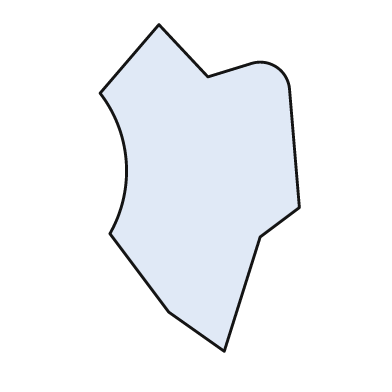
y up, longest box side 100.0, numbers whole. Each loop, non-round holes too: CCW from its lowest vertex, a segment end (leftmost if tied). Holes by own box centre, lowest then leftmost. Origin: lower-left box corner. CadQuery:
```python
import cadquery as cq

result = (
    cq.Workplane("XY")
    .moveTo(38.0, 0.0)
    .lineTo(49.0, 35.0)
    .lineTo(61.0, 44.0)
    .lineTo(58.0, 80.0)
    .threePointArc((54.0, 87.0), (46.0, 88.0))
    .lineTo(33.0, 84.0)
    .lineTo(18.0, 100.0)
    .lineTo(0.0, 79.0)
    .threePointArc((8.0, 58.0), (3.0, 36.0))
    .lineTo(21.0, 12.0)
    .close()
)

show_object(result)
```